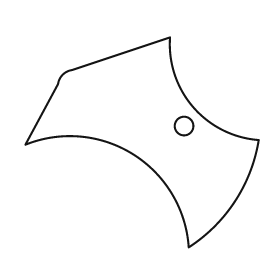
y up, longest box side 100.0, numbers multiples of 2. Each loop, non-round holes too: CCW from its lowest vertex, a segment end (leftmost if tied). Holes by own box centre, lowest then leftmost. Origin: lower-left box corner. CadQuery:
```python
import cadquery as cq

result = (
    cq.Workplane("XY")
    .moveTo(70.0, 0.0)
    .threePointArc((90.0, 20.0), (100.0, 46.0))
    .threePointArc((72.0, 60.0), (62.0, 90.0))
    .lineTo(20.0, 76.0)
    .threePointArc((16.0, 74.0), (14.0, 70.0))
    .lineTo(0.0, 44.0)
    .threePointArc((46.0, 40.0), (70.0, 0.0))
    .close()
    .moveTo(68.0, 52.0)
    .circle(4.0)
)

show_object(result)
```